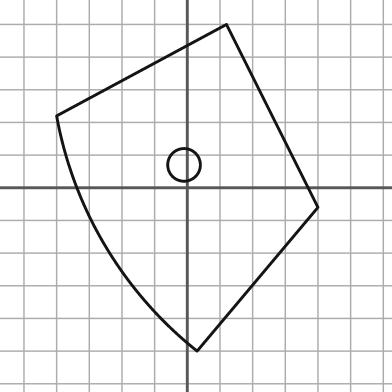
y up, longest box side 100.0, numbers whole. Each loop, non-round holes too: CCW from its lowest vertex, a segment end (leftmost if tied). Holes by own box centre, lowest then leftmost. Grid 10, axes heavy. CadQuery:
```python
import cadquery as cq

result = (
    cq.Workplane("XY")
    .moveTo(3.0, -50.0)
    .lineTo(40.0, -6.0)
    .lineTo(12.0, 50.0)
    .lineTo(-40.0, 22.0)
    .threePointArc((-25.0, -18.0), (3.0, -50.0))
    .close()
    .moveTo(-1.0, 7.0)
    .circle(5.0)
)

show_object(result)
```